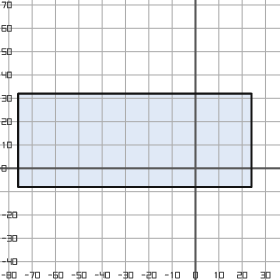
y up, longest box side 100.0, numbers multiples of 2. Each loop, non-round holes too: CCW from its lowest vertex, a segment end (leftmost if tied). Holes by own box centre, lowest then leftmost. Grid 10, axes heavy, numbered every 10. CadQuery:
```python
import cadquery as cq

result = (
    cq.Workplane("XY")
    .moveTo(-76.0, -8.0)
    .lineTo(24.0, -8.0)
    .lineTo(24.0, 32.0)
    .lineTo(-76.0, 32.0)
    .close()
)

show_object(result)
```